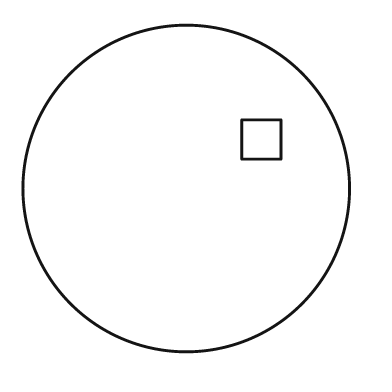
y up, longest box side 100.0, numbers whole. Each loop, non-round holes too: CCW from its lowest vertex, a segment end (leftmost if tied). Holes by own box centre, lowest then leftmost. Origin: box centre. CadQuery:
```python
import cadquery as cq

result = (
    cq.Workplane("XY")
    .moveTo(0.0, 0.0)
    .circle(50.0)
    .moveTo(17.0, 9.0)
    .lineTo(29.0, 9.0)
    .lineTo(29.0, 21.0)
    .lineTo(17.0, 21.0)
    .close()
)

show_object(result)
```